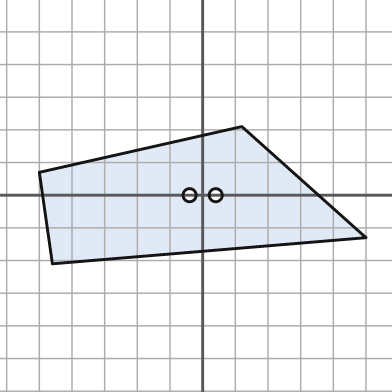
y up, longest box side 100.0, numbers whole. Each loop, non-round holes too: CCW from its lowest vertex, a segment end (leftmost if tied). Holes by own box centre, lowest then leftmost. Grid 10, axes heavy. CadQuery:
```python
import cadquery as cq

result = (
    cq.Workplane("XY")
    .moveTo(-46.0, -21.0)
    .lineTo(50.0, -13.0)
    .lineTo(12.0, 21.0)
    .lineTo(-50.0, 7.0)
    .close()
    .moveTo(-4.0, 0.0)
    .circle(2.0)
    .moveTo(4.0, 0.0)
    .circle(2.0)
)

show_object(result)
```